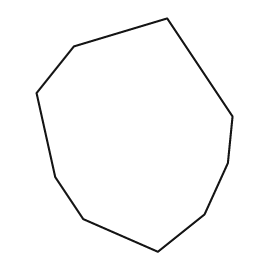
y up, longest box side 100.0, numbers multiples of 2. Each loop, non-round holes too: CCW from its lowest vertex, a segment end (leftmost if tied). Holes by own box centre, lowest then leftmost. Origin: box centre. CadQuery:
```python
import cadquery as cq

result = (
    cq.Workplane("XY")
    .moveTo(10.0, -50.0)
    .lineTo(30.0, -34.0)
    .lineTo(40.0, -12.0)
    .lineTo(42.0, 8.0)
    .lineTo(14.0, 50.0)
    .lineTo(-26.0, 38.0)
    .lineTo(-42.0, 18.0)
    .lineTo(-34.0, -18.0)
    .lineTo(-22.0, -36.0)
    .close()
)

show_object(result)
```